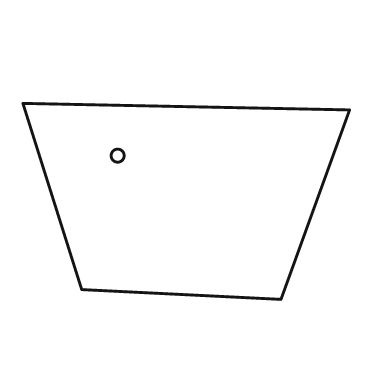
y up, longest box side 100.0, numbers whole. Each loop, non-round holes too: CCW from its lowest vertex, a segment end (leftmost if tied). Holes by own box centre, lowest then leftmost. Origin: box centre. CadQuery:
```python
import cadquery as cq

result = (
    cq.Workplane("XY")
    .moveTo(29.0, -30.0)
    .lineTo(50.0, 28.0)
    .lineTo(-50.0, 30.0)
    .lineTo(-32.0, -27.0)
    .close()
    .moveTo(-21.0, 14.0)
    .circle(2.0)
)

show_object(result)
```